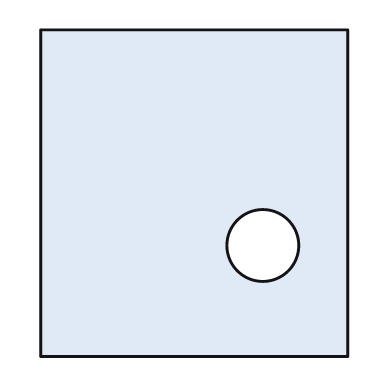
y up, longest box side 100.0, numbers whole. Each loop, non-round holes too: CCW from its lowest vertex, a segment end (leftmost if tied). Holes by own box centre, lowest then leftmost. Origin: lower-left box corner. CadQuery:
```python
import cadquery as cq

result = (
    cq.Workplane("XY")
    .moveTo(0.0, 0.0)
    .lineTo(94.0, 0.0)
    .lineTo(94.0, 100.0)
    .lineTo(0.0, 100.0)
    .close()
    .moveTo(68.0, 34.0)
    .circle(11.0)
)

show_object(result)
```